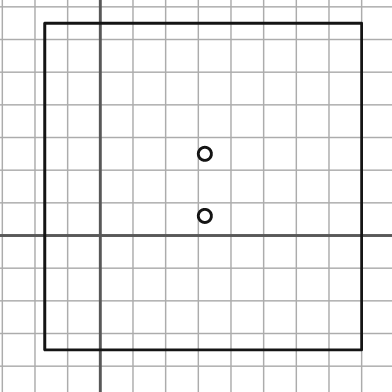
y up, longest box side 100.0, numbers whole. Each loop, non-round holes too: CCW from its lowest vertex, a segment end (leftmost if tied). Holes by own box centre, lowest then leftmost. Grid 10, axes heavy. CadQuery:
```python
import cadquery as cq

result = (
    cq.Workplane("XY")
    .moveTo(-17.0, -35.0)
    .lineTo(80.0, -35.0)
    .lineTo(80.0, 65.0)
    .lineTo(-17.0, 65.0)
    .close()
    .moveTo(32.0, 6.0)
    .circle(2.0)
    .moveTo(32.0, 25.0)
    .circle(2.0)
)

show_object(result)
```